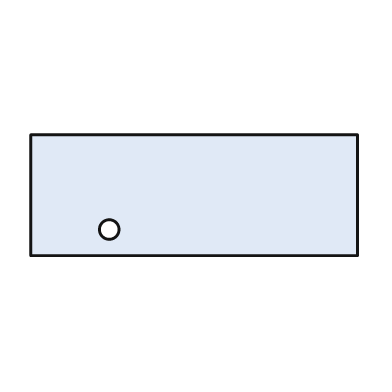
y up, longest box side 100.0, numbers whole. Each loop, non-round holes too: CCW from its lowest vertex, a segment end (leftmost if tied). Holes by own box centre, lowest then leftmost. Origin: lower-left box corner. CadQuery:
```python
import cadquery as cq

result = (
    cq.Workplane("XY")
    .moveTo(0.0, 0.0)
    .lineTo(100.0, 0.0)
    .lineTo(100.0, 37.0)
    .lineTo(0.0, 37.0)
    .close()
    .moveTo(24.0, 8.0)
    .circle(3.0)
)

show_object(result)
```